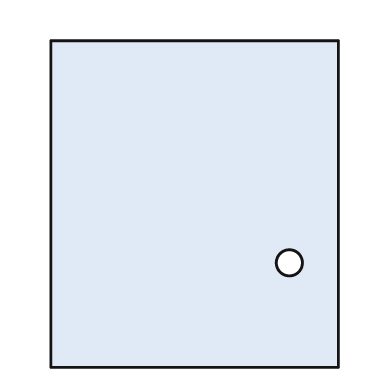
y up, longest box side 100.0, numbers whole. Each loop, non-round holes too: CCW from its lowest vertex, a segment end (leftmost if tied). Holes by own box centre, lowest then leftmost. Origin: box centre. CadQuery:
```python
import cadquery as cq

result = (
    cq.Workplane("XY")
    .moveTo(-44.0, -50.0)
    .lineTo(44.0, -50.0)
    .lineTo(44.0, 50.0)
    .lineTo(-44.0, 50.0)
    .close()
    .moveTo(29.0, -18.0)
    .circle(4.0)
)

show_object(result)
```